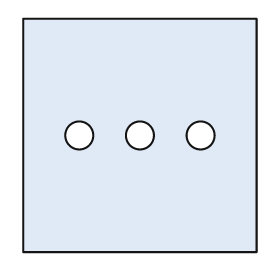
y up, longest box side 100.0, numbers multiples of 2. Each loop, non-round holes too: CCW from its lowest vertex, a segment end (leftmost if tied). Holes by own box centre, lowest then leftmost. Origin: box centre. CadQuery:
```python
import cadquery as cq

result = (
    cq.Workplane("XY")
    .moveTo(-50.0, -50.0)
    .lineTo(50.0, -50.0)
    .lineTo(50.0, 50.0)
    .lineTo(-50.0, 50.0)
    .close()
    .moveTo(-26.0, 0.0)
    .circle(6.0)
    .moveTo(0.0, 0.0)
    .circle(6.0)
    .moveTo(26.0, 0.0)
    .circle(6.0)
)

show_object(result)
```